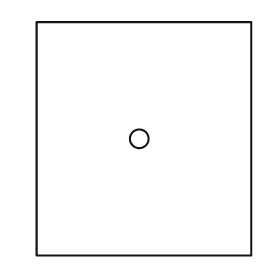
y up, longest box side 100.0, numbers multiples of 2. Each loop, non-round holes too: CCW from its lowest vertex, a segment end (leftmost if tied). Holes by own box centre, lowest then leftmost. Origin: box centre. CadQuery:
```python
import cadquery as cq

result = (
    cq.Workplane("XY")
    .moveTo(-46.0, -50.0)
    .lineTo(46.0, -50.0)
    .lineTo(46.0, 50.0)
    .lineTo(-46.0, 50.0)
    .close()
    .moveTo(-2.0, 0.0)
    .circle(4.0)
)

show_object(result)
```